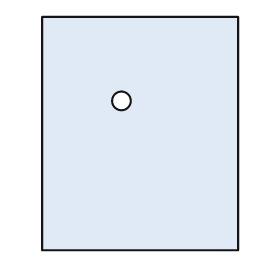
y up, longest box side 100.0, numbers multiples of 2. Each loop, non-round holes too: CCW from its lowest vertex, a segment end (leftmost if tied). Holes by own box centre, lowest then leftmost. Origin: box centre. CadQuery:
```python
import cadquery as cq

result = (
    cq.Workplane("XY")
    .moveTo(-42.0, -50.0)
    .lineTo(42.0, -50.0)
    .lineTo(42.0, 50.0)
    .lineTo(-42.0, 50.0)
    .close()
    .moveTo(-8.0, 14.0)
    .circle(4.0)
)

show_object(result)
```